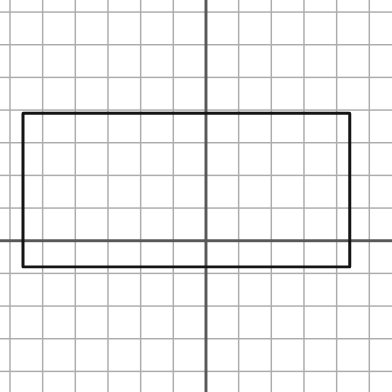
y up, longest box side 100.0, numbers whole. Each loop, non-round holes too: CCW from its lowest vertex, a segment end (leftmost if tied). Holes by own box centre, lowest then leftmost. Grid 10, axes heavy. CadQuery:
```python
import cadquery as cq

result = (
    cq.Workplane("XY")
    .moveTo(-56.0, -8.0)
    .lineTo(44.0, -8.0)
    .lineTo(44.0, 39.0)
    .lineTo(-56.0, 39.0)
    .close()
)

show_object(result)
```